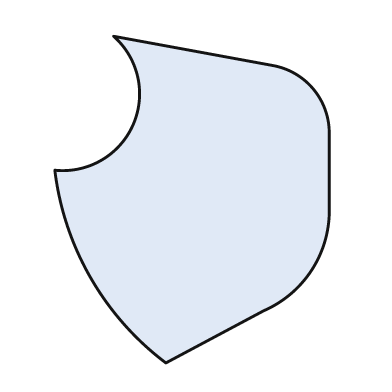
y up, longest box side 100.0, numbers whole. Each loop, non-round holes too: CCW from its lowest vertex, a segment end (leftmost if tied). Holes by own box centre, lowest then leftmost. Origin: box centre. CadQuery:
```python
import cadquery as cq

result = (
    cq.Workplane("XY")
    .moveTo(-8.0, -50.0)
    .lineTo(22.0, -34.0)
    .threePointArc((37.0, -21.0), (42.0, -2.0))
    .lineTo(42.0, 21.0)
    .threePointArc((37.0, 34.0), (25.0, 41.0))
    .lineTo(-24.0, 50.0)
    .threePointArc((-18.0, 23.0), (-42.0, 9.0))
    .threePointArc((-31.0, -24.0), (-8.0, -50.0))
    .close()
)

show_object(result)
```